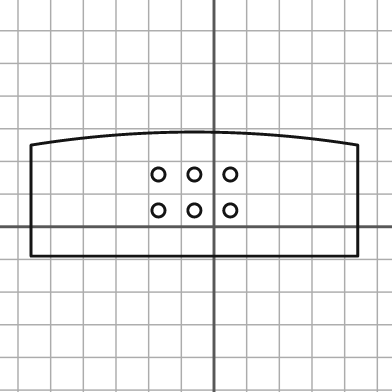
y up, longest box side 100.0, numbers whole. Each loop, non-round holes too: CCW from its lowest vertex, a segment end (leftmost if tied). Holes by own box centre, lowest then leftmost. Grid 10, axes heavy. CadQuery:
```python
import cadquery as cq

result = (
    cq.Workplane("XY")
    .moveTo(-56.0, -9.0)
    .lineTo(44.0, -9.0)
    .lineTo(44.0, 25.0)
    .threePointArc((-6.0, 29.0), (-56.0, 25.0))
    .close()
    .moveTo(-17.0, 5.0)
    .circle(2.0)
    .moveTo(-6.0, 5.0)
    .circle(2.0)
    .moveTo(5.0, 5.0)
    .circle(2.0)
    .moveTo(-17.0, 16.0)
    .circle(2.0)
    .moveTo(-6.0, 16.0)
    .circle(2.0)
    .moveTo(5.0, 16.0)
    .circle(2.0)
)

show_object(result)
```